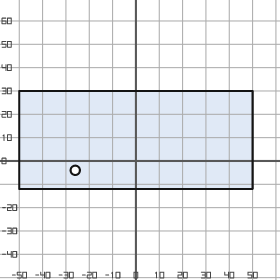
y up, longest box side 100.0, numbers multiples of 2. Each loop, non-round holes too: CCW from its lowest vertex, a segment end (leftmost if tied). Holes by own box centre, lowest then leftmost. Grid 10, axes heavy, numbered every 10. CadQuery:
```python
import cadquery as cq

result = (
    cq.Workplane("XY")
    .moveTo(-50.0, -12.0)
    .lineTo(50.0, -12.0)
    .lineTo(50.0, 30.0)
    .lineTo(-50.0, 30.0)
    .close()
    .moveTo(-26.0, -4.0)
    .circle(2.0)
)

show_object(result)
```